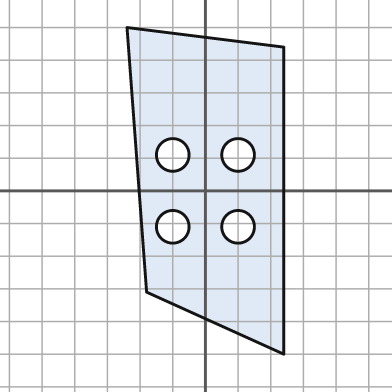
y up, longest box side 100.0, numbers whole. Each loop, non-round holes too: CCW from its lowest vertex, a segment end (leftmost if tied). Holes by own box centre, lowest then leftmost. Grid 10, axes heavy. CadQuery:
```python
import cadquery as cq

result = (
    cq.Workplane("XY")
    .moveTo(24.0, -50.0)
    .lineTo(24.0, 44.0)
    .lineTo(-24.0, 50.0)
    .lineTo(-18.0, -31.0)
    .close()
    .moveTo(-10.0, -11.0)
    .circle(5.0)
    .moveTo(10.0, -11.0)
    .circle(5.0)
    .moveTo(-10.0, 11.0)
    .circle(5.0)
    .moveTo(10.0, 11.0)
    .circle(5.0)
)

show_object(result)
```